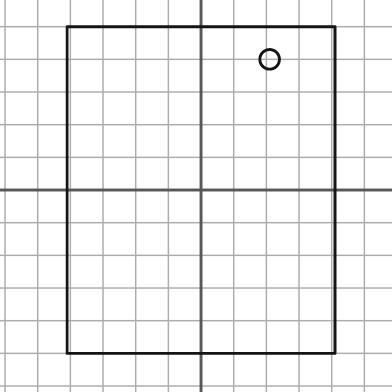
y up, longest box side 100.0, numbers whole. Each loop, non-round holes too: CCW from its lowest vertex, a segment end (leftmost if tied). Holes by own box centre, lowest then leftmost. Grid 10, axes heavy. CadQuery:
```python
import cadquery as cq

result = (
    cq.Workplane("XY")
    .moveTo(-41.0, -50.0)
    .lineTo(41.0, -50.0)
    .lineTo(41.0, 50.0)
    .lineTo(-41.0, 50.0)
    .close()
    .moveTo(21.0, 40.0)
    .circle(3.0)
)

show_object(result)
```